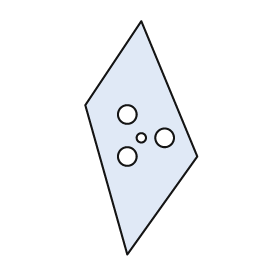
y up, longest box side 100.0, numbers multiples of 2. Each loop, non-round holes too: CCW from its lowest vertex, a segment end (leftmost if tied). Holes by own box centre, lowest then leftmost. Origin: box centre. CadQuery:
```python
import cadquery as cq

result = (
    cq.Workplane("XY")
    .moveTo(-6.0, -50.0)
    .lineTo(24.0, -8.0)
    .lineTo(0.0, 50.0)
    .lineTo(-24.0, 14.0)
    .close()
    .moveTo(-6.0, -8.0)
    .circle(4.0)
    .moveTo(0.0, 0.0)
    .circle(2.0)
    .moveTo(10.0, 0.0)
    .circle(4.0)
    .moveTo(-6.0, 10.0)
    .circle(4.0)
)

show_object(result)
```